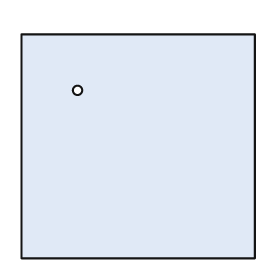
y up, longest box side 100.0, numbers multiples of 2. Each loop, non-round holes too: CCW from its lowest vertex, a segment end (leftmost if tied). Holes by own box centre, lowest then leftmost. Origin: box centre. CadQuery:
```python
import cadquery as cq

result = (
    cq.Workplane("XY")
    .moveTo(-50.0, -48.0)
    .lineTo(50.0, -48.0)
    .lineTo(50.0, 48.0)
    .lineTo(-50.0, 48.0)
    .close()
    .moveTo(-26.0, 24.0)
    .circle(2.0)
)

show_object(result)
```